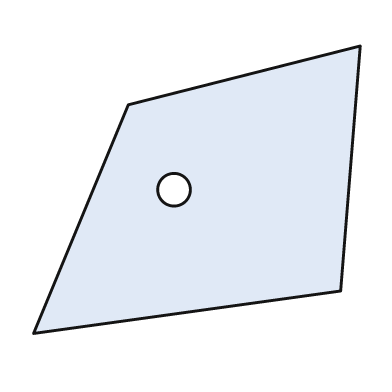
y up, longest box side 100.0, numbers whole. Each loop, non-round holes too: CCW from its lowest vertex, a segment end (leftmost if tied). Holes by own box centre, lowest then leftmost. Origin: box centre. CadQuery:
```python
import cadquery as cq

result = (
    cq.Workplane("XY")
    .moveTo(-50.0, -44.0)
    .lineTo(44.0, -31.0)
    .lineTo(50.0, 44.0)
    .lineTo(-21.0, 26.0)
    .close()
    .moveTo(-7.0, 0.0)
    .circle(5.0)
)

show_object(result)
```